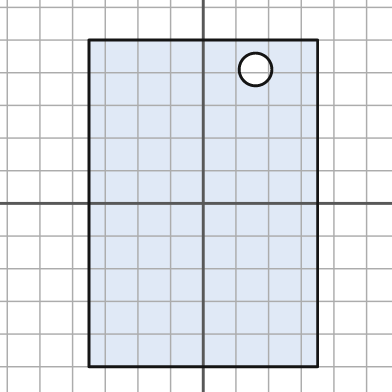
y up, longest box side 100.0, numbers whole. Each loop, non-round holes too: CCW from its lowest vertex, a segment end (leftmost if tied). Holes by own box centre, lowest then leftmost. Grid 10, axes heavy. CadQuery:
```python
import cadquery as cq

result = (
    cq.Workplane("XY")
    .moveTo(-35.0, -50.0)
    .lineTo(35.0, -50.0)
    .lineTo(35.0, 50.0)
    .lineTo(-35.0, 50.0)
    .close()
    .moveTo(16.0, 41.0)
    .circle(5.0)
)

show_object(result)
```